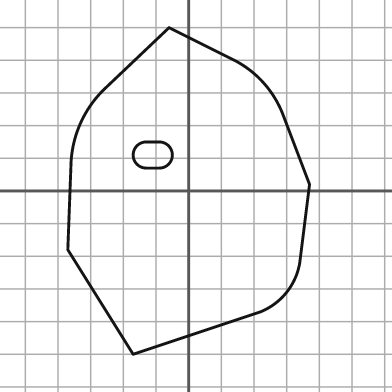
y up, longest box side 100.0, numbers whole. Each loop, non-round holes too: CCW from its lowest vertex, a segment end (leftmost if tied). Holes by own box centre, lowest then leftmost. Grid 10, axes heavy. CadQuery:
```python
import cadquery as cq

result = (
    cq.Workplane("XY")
    .moveTo(-17.0, -50.0)
    .lineTo(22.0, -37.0)
    .threePointArc((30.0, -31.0), (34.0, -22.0))
    .lineTo(37.0, 2.0)
    .lineTo(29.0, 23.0)
    .threePointArc((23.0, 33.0), (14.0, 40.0))
    .lineTo(-6.0, 50.0)
    .lineTo(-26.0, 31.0)
    .threePointArc((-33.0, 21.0), (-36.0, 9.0))
    .lineTo(-37.0, -18.0)
    .close()
    .moveTo(-13.0, 7.0)
    .lineTo(-9.0, 7.0)
    .threePointArc((-5.0, 11.0), (-9.0, 15.0))
    .lineTo(-13.0, 15.0)
    .threePointArc((-17.0, 11.0), (-13.0, 7.0))
    .close()
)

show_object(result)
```